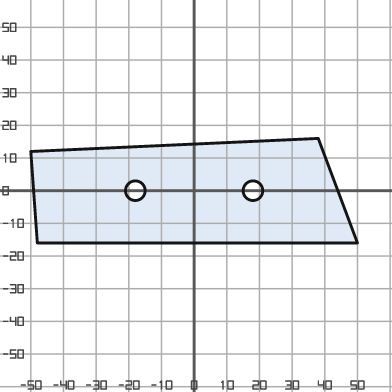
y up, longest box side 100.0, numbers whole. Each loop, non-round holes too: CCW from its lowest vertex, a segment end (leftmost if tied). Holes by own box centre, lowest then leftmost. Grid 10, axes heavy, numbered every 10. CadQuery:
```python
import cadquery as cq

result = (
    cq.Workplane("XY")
    .moveTo(-48.0, -16.0)
    .lineTo(50.0, -16.0)
    .lineTo(38.0, 16.0)
    .lineTo(-50.0, 12.0)
    .close()
    .moveTo(-18.0, 0.0)
    .circle(3.0)
    .moveTo(18.0, 0.0)
    .circle(3.0)
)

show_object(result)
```